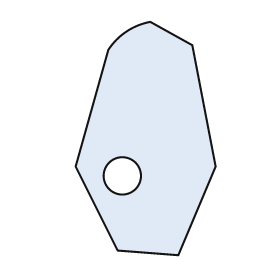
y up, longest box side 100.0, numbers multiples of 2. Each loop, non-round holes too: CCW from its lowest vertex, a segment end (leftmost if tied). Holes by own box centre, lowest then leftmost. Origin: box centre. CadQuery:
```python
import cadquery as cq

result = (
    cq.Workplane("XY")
    .moveTo(14.0, -50.0)
    .lineTo(30.0, -12.0)
    .lineTo(20.0, 40.0)
    .lineTo(2.0, 50.0)
    .threePointArc((-8.0, 46.0), (-16.0, 38.0))
    .lineTo(-30.0, -12.0)
    .lineTo(-12.0, -48.0)
    .close()
    .moveTo(-10.0, -16.0)
    .circle(8.0)
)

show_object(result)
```